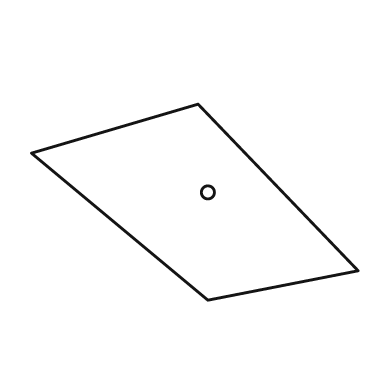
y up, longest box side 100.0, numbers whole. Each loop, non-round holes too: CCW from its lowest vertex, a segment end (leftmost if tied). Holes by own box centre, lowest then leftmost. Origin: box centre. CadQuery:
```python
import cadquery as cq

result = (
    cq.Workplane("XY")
    .moveTo(4.0, -30.0)
    .lineTo(50.0, -21.0)
    .lineTo(1.0, 30.0)
    .lineTo(-50.0, 15.0)
    .close()
    .moveTo(4.0, 3.0)
    .circle(2.0)
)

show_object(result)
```